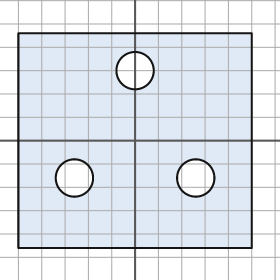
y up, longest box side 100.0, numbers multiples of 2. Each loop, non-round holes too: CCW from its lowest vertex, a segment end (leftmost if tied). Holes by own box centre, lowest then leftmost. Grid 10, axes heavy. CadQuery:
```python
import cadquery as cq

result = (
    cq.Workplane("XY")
    .moveTo(-50.0, -46.0)
    .lineTo(50.0, -46.0)
    .lineTo(50.0, 46.0)
    .lineTo(-50.0, 46.0)
    .close()
    .moveTo(-26.0, -16.0)
    .circle(8.0)
    .moveTo(26.0, -16.0)
    .circle(8.0)
    .moveTo(0.0, 30.0)
    .circle(8.0)
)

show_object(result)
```